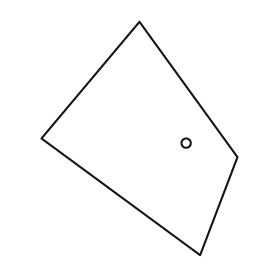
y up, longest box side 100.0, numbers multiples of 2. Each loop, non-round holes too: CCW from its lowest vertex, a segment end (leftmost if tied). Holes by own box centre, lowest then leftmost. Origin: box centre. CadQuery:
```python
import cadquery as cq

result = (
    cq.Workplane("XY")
    .moveTo(26.0, -50.0)
    .lineTo(42.0, -8.0)
    .lineTo(0.0, 50.0)
    .lineTo(-42.0, 0.0)
    .close()
    .moveTo(20.0, -2.0)
    .circle(2.0)
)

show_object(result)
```